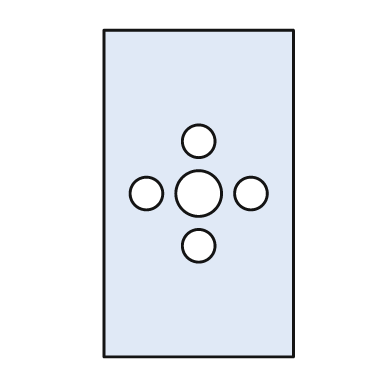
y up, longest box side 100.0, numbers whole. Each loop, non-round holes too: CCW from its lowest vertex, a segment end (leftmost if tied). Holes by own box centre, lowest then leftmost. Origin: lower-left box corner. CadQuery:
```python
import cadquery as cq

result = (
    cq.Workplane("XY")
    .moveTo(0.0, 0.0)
    .lineTo(58.0, 0.0)
    .lineTo(58.0, 100.0)
    .lineTo(0.0, 100.0)
    .close()
    .moveTo(29.0, 34.0)
    .circle(5.0)
    .moveTo(13.0, 50.0)
    .circle(5.0)
    .moveTo(29.0, 50.0)
    .circle(7.0)
    .moveTo(45.0, 50.0)
    .circle(5.0)
    .moveTo(29.0, 66.0)
    .circle(5.0)
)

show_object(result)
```